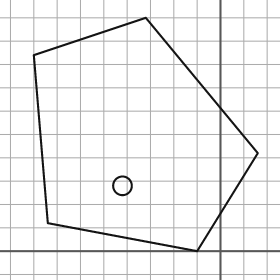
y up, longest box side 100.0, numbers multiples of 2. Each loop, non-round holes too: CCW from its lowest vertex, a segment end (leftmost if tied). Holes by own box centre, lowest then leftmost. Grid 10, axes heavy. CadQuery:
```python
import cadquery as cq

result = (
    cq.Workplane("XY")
    .moveTo(-10.0, 0.0)
    .lineTo(16.0, 42.0)
    .lineTo(-32.0, 100.0)
    .lineTo(-80.0, 84.0)
    .lineTo(-74.0, 12.0)
    .close()
    .moveTo(-42.0, 28.0)
    .circle(4.0)
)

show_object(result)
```